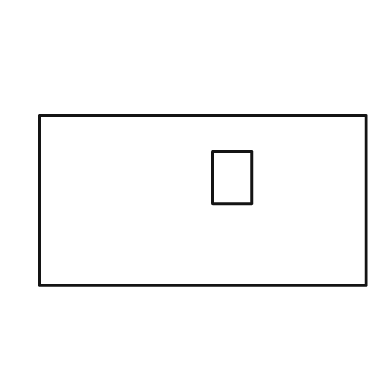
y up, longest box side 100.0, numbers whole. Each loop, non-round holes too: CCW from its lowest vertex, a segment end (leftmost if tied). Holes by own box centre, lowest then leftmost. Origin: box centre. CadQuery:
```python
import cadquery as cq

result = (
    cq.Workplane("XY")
    .moveTo(-50.0, -26.0)
    .lineTo(50.0, -26.0)
    .lineTo(50.0, 26.0)
    .lineTo(-50.0, 26.0)
    .close()
    .moveTo(3.0, -1.0)
    .lineTo(15.0, -1.0)
    .lineTo(15.0, 15.0)
    .lineTo(3.0, 15.0)
    .close()
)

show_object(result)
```